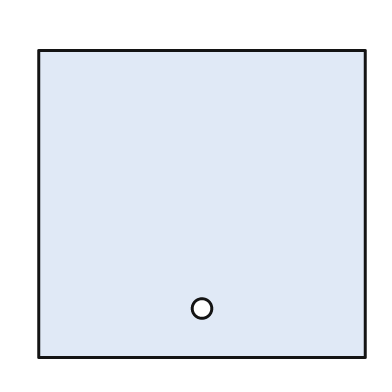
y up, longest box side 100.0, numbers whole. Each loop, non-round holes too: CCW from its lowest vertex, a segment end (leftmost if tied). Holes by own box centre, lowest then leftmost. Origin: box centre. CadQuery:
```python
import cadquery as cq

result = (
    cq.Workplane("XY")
    .moveTo(-50.0, -47.0)
    .lineTo(50.0, -47.0)
    .lineTo(50.0, 47.0)
    .lineTo(-50.0, 47.0)
    .close()
    .moveTo(0.0, -32.0)
    .circle(3.0)
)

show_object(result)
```